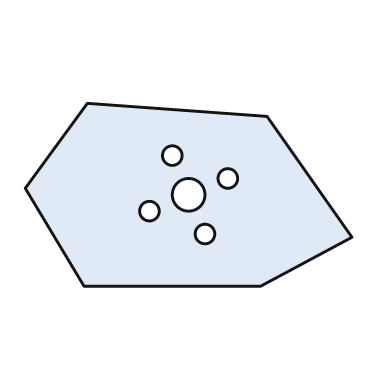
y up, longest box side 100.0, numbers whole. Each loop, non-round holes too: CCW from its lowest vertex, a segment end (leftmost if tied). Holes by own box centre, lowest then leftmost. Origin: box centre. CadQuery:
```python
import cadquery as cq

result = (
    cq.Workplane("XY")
    .moveTo(-32.0, -28.0)
    .lineTo(22.0, -28.0)
    .lineTo(50.0, -13.0)
    .lineTo(24.0, 24.0)
    .lineTo(-31.0, 28.0)
    .lineTo(-50.0, 2.0)
    .close()
    .moveTo(5.0, -12.0)
    .circle(3.0)
    .moveTo(-12.0, -5.0)
    .circle(3.0)
    .moveTo(0.0, 0.0)
    .circle(5.0)
    .moveTo(12.0, 5.0)
    .circle(3.0)
    .moveTo(-5.0, 12.0)
    .circle(3.0)
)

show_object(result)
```